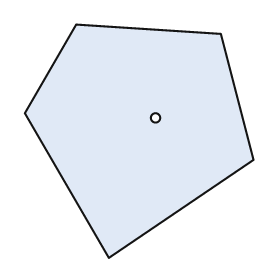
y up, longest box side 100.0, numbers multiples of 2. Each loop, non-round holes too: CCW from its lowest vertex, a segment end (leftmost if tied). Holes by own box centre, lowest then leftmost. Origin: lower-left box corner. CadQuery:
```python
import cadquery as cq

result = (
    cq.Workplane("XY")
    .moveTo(36.0, 0.0)
    .lineTo(98.0, 42.0)
    .lineTo(84.0, 96.0)
    .lineTo(22.0, 100.0)
    .lineTo(0.0, 62.0)
    .close()
    .moveTo(56.0, 60.0)
    .circle(2.0)
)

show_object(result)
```